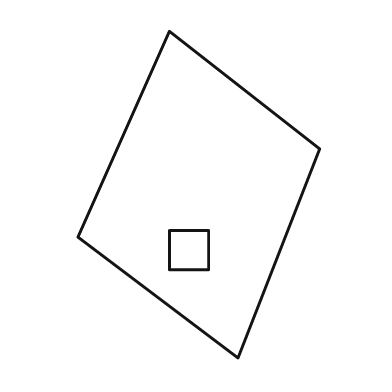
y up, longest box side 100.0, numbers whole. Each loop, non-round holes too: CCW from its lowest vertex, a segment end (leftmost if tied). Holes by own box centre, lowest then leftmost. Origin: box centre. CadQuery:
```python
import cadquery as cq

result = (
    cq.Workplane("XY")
    .moveTo(12.0, -50.0)
    .lineTo(37.0, 14.0)
    .lineTo(-9.0, 50.0)
    .lineTo(-37.0, -13.0)
    .close()
    .moveTo(-9.0, -23.0)
    .lineTo(3.0, -23.0)
    .lineTo(3.0, -11.0)
    .lineTo(-9.0, -11.0)
    .close()
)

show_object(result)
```